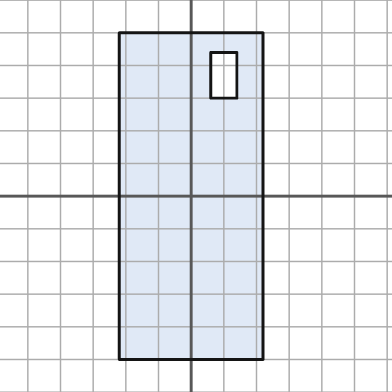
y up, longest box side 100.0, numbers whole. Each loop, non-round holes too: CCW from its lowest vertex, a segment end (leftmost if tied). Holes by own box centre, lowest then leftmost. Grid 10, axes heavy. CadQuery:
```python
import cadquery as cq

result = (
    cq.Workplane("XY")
    .moveTo(-22.0, -50.0)
    .lineTo(22.0, -50.0)
    .lineTo(22.0, 50.0)
    .lineTo(-22.0, 50.0)
    .close()
    .moveTo(6.0, 30.0)
    .lineTo(14.0, 30.0)
    .lineTo(14.0, 44.0)
    .lineTo(6.0, 44.0)
    .close()
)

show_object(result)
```